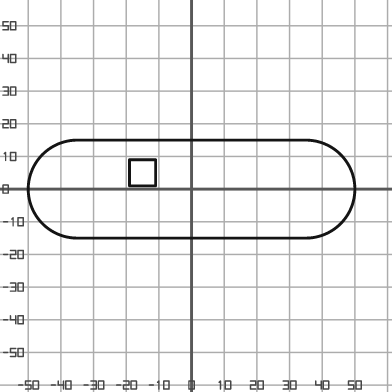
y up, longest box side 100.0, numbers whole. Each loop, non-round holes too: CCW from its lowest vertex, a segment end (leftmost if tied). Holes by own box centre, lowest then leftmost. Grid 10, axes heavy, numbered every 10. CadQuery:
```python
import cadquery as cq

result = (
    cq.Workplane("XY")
    .moveTo(-35.0, -15.0)
    .lineTo(35.0, -15.0)
    .threePointArc((50.0, 0.0), (35.0, 15.0))
    .lineTo(-35.0, 15.0)
    .threePointArc((-50.0, 0.0), (-35.0, -15.0))
    .close()
    .moveTo(-19.0, 1.0)
    .lineTo(-11.0, 1.0)
    .lineTo(-11.0, 9.0)
    .lineTo(-19.0, 9.0)
    .close()
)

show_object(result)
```